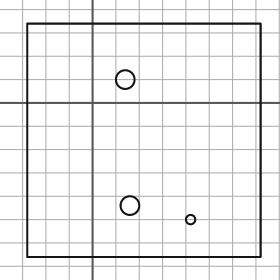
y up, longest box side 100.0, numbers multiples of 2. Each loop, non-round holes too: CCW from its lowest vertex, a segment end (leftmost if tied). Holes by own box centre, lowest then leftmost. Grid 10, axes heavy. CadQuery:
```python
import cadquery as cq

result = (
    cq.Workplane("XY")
    .moveTo(-28.0, -66.0)
    .lineTo(72.0, -66.0)
    .lineTo(72.0, 34.0)
    .lineTo(-28.0, 34.0)
    .close()
    .moveTo(42.0, -50.0)
    .circle(2.0)
    .moveTo(16.0, -44.0)
    .circle(4.0)
    .moveTo(14.0, 10.0)
    .circle(4.0)
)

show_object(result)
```